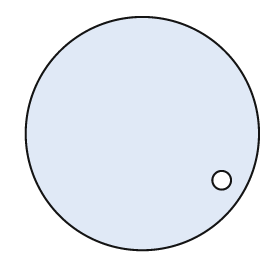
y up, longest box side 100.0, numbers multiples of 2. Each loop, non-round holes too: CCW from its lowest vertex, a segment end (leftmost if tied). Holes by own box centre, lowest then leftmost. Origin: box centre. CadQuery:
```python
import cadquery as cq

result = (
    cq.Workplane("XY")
    .moveTo(0.0, 0.0)
    .circle(50.0)
    .moveTo(34.0, -20.0)
    .circle(4.0)
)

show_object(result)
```